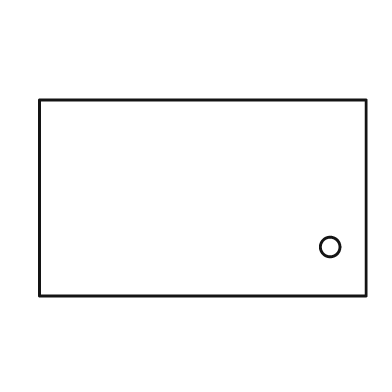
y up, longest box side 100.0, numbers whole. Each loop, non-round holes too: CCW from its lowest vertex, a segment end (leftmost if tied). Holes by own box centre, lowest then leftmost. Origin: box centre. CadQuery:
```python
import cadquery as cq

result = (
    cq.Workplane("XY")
    .moveTo(-50.0, -30.0)
    .lineTo(50.0, -30.0)
    .lineTo(50.0, 30.0)
    .lineTo(-50.0, 30.0)
    .close()
    .moveTo(39.0, -15.0)
    .circle(3.0)
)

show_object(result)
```